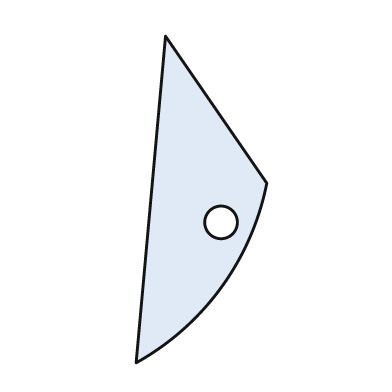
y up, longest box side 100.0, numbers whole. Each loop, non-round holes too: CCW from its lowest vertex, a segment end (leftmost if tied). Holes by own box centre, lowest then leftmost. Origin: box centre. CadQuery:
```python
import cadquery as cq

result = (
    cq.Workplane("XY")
    .moveTo(-20.0, -50.0)
    .threePointArc((6.0, -27.0), (20.0, 5.0))
    .lineTo(-11.0, 50.0)
    .close()
    .moveTo(6.0, -7.0)
    .circle(5.0)
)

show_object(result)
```